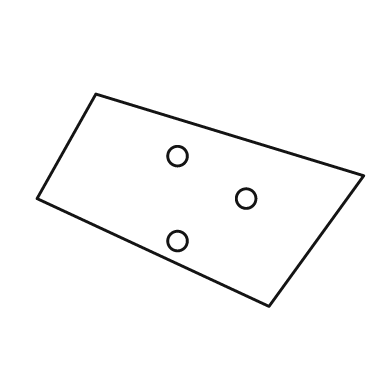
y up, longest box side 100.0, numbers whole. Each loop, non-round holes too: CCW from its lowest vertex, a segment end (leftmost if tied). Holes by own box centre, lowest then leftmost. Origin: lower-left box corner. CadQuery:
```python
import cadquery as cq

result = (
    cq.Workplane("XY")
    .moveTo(71.0, 0.0)
    .lineTo(100.0, 40.0)
    .lineTo(18.0, 65.0)
    .lineTo(0.0, 33.0)
    .close()
    .moveTo(43.0, 20.0)
    .circle(3.0)
    .moveTo(64.0, 33.0)
    .circle(3.0)
    .moveTo(43.0, 46.0)
    .circle(3.0)
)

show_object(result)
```